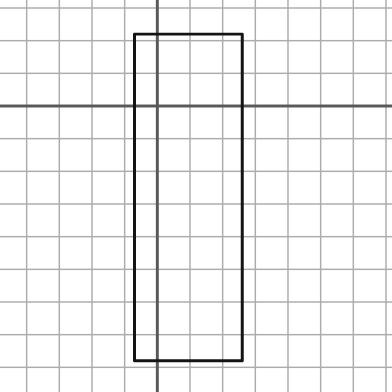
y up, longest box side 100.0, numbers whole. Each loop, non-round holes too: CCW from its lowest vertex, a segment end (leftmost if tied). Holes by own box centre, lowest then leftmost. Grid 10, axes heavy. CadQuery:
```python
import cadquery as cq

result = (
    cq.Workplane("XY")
    .moveTo(-7.0, -78.0)
    .lineTo(26.0, -78.0)
    .lineTo(26.0, 22.0)
    .lineTo(-7.0, 22.0)
    .close()
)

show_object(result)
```